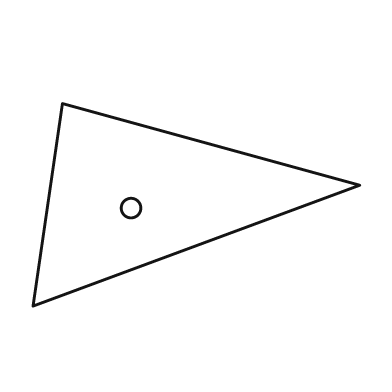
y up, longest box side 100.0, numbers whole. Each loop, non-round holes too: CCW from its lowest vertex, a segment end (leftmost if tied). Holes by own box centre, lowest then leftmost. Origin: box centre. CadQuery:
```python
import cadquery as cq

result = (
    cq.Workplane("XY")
    .moveTo(-50.0, -31.0)
    .lineTo(50.0, 6.0)
    .lineTo(-41.0, 31.0)
    .close()
    .moveTo(-20.0, -1.0)
    .circle(3.0)
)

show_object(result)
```